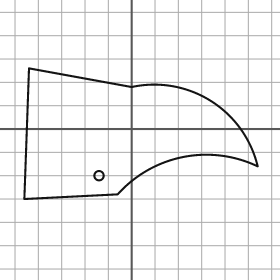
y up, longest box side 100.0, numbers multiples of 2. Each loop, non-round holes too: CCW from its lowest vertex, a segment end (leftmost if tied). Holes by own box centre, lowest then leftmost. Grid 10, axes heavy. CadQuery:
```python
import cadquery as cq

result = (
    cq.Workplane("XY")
    .moveTo(-46.0, -30.0)
    .lineTo(-6.0, -28.0)
    .threePointArc((22.0, -12.0), (54.0, -16.0))
    .threePointArc((34.0, 12.0), (0.0, 18.0))
    .lineTo(-44.0, 26.0)
    .close()
    .moveTo(-14.0, -20.0)
    .circle(2.0)
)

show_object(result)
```